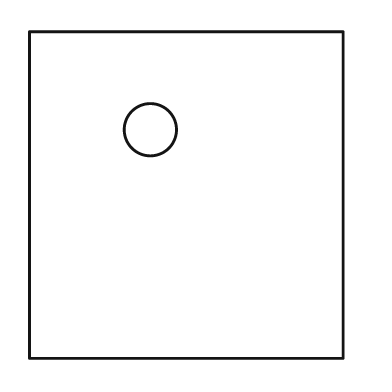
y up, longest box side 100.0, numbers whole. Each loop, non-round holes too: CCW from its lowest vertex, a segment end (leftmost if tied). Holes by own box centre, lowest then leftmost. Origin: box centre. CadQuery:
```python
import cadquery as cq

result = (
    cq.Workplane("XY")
    .moveTo(-48.0, -50.0)
    .lineTo(48.0, -50.0)
    .lineTo(48.0, 50.0)
    .lineTo(-48.0, 50.0)
    .close()
    .moveTo(-11.0, 20.0)
    .circle(8.0)
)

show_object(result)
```